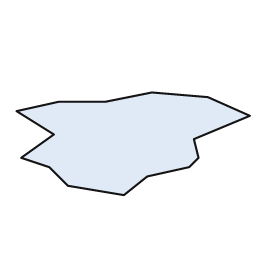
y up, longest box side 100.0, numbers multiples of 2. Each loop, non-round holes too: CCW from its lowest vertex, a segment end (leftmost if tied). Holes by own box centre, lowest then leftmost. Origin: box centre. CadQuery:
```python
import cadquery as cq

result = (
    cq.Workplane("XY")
    .moveTo(-4.0, -22.0)
    .lineTo(6.0, -14.0)
    .lineTo(24.0, -10.0)
    .lineTo(28.0, -6.0)
    .lineTo(26.0, 2.0)
    .lineTo(50.0, 12.0)
    .lineTo(32.0, 20.0)
    .lineTo(8.0, 22.0)
    .lineTo(-12.0, 18.0)
    .lineTo(-32.0, 18.0)
    .lineTo(-50.0, 14.0)
    .lineTo(-34.0, 4.0)
    .lineTo(-48.0, -6.0)
    .lineTo(-36.0, -10.0)
    .lineTo(-28.0, -18.0)
    .close()
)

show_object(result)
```